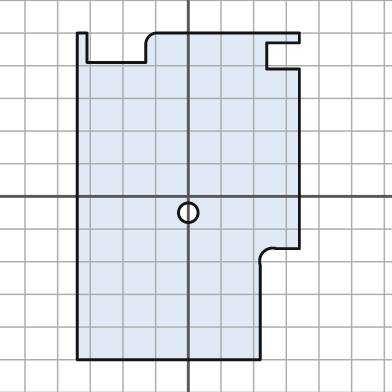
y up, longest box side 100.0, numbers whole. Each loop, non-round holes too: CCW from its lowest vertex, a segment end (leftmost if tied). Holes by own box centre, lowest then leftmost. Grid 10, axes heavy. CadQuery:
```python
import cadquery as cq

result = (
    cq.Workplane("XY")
    .moveTo(-34.0, -50.0)
    .lineTo(22.0, -50.0)
    .lineTo(22.0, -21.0)
    .threePointArc((23.0, -17.0), (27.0, -16.0))
    .lineTo(34.0, -16.0)
    .lineTo(34.0, 39.0)
    .lineTo(24.0, 39.0)
    .lineTo(24.0, 47.0)
    .lineTo(34.0, 47.0)
    .lineTo(34.0, 50.0)
    .lineTo(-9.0, 50.0)
    .threePointArc((-12.0, 49.0), (-13.0, 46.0))
    .lineTo(-13.0, 41.0)
    .lineTo(-31.0, 41.0)
    .lineTo(-31.0, 50.0)
    .lineTo(-34.0, 50.0)
    .close()
    .moveTo(0.0, -5.0)
    .circle(3.0)
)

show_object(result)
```